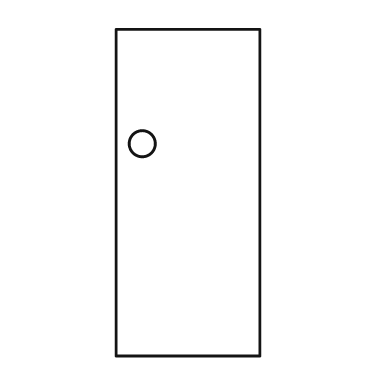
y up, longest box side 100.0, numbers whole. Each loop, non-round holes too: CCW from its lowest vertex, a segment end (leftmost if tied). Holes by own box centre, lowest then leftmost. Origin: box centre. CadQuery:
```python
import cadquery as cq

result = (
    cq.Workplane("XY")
    .moveTo(-22.0, -50.0)
    .lineTo(22.0, -50.0)
    .lineTo(22.0, 50.0)
    .lineTo(-22.0, 50.0)
    .close()
    .moveTo(-14.0, 15.0)
    .circle(4.0)
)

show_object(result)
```